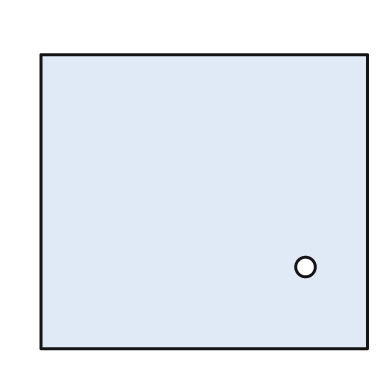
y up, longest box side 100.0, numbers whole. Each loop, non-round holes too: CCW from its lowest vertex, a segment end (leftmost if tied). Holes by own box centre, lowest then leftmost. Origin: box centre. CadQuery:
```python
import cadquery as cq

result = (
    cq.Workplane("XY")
    .moveTo(-50.0, -45.0)
    .lineTo(50.0, -45.0)
    .lineTo(50.0, 45.0)
    .lineTo(-50.0, 45.0)
    .close()
    .moveTo(31.0, -20.0)
    .circle(3.0)
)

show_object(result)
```